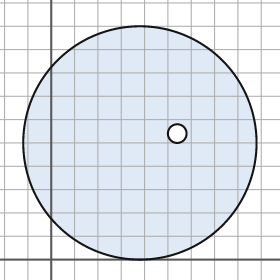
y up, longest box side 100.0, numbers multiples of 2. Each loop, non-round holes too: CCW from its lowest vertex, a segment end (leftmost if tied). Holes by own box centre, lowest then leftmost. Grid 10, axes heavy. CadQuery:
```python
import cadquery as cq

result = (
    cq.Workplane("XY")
    .moveTo(38.0, 50.0)
    .circle(50.0)
    .moveTo(54.0, 54.0)
    .circle(4.0)
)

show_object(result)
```